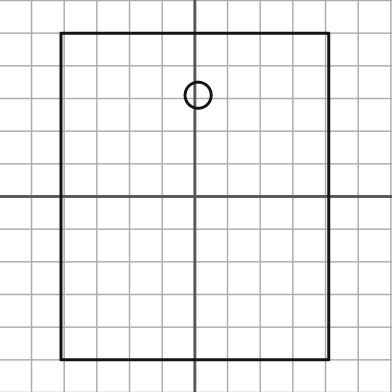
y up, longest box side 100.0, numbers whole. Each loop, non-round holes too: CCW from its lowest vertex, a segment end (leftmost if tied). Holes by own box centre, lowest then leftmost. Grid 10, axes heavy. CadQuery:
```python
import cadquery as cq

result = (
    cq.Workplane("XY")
    .moveTo(-41.0, -50.0)
    .lineTo(41.0, -50.0)
    .lineTo(41.0, 50.0)
    .lineTo(-41.0, 50.0)
    .close()
    .moveTo(1.0, 31.0)
    .circle(4.0)
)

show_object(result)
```